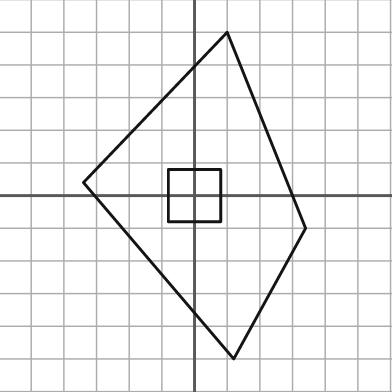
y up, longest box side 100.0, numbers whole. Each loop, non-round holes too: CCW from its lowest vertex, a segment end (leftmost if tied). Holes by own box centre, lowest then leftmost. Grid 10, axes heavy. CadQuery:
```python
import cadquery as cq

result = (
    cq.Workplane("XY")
    .moveTo(12.0, -50.0)
    .lineTo(34.0, -10.0)
    .lineTo(10.0, 50.0)
    .lineTo(-34.0, 4.0)
    .close()
    .moveTo(-8.0, -8.0)
    .lineTo(8.0, -8.0)
    .lineTo(8.0, 8.0)
    .lineTo(-8.0, 8.0)
    .close()
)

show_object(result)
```